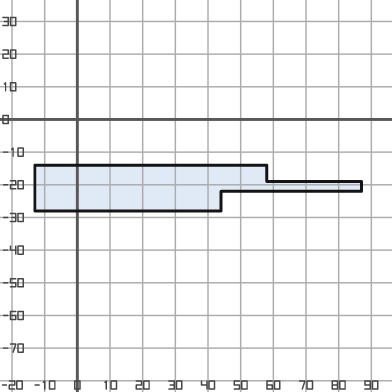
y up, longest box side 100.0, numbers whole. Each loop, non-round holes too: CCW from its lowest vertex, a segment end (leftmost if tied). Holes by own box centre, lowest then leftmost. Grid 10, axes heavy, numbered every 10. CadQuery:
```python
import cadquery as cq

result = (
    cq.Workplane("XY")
    .moveTo(-13.0, -28.0)
    .lineTo(44.0, -28.0)
    .lineTo(44.0, -22.0)
    .lineTo(87.0, -22.0)
    .lineTo(87.0, -19.0)
    .lineTo(58.0, -19.0)
    .lineTo(58.0, -14.0)
    .lineTo(-13.0, -14.0)
    .close()
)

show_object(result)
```